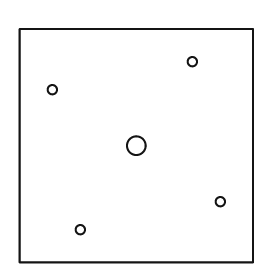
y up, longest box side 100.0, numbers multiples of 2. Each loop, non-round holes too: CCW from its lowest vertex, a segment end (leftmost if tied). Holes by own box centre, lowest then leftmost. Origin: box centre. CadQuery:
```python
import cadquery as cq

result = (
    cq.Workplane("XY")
    .moveTo(-50.0, -50.0)
    .lineTo(50.0, -50.0)
    .lineTo(50.0, 50.0)
    .lineTo(-50.0, 50.0)
    .close()
    .moveTo(-24.0, -36.0)
    .circle(2.0)
    .moveTo(36.0, -24.0)
    .circle(2.0)
    .moveTo(0.0, 0.0)
    .circle(4.0)
    .moveTo(-36.0, 24.0)
    .circle(2.0)
    .moveTo(24.0, 36.0)
    .circle(2.0)
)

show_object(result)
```